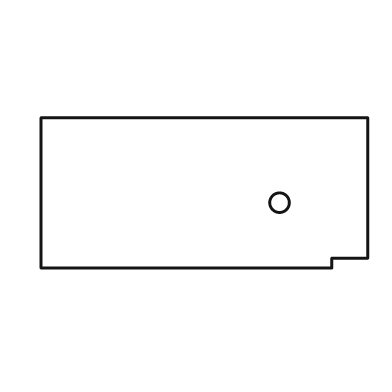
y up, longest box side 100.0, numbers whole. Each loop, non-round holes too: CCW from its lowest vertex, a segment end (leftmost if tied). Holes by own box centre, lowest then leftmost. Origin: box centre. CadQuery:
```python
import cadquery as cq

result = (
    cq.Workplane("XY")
    .moveTo(-50.0, -23.0)
    .lineTo(39.0, -23.0)
    .lineTo(39.0, -20.0)
    .lineTo(50.0, -20.0)
    .lineTo(50.0, 23.0)
    .lineTo(-50.0, 23.0)
    .close()
    .moveTo(23.0, -3.0)
    .circle(3.0)
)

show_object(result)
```